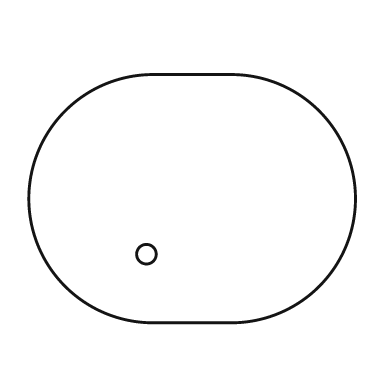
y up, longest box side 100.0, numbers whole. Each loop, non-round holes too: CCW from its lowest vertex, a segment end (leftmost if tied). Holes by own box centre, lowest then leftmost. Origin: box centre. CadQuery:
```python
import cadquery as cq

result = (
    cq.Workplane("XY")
    .moveTo(-12.0, -38.0)
    .lineTo(12.0, -38.0)
    .threePointArc((50.0, 0.0), (12.0, 38.0))
    .lineTo(-12.0, 38.0)
    .threePointArc((-50.0, 0.0), (-12.0, -38.0))
    .close()
    .moveTo(-14.0, -17.0)
    .circle(3.0)
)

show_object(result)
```